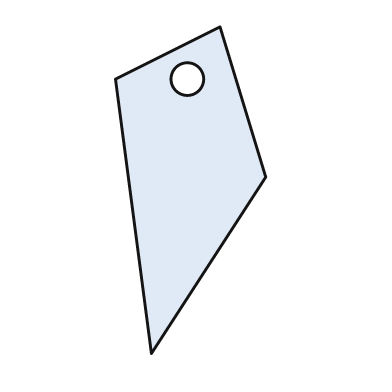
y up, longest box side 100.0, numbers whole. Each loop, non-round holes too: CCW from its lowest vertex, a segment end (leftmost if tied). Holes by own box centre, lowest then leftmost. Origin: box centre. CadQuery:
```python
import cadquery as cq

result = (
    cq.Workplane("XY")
    .moveTo(-12.0, -50.0)
    .lineTo(23.0, 4.0)
    .lineTo(9.0, 50.0)
    .lineTo(-23.0, 34.0)
    .close()
    .moveTo(-1.0, 34.0)
    .circle(5.0)
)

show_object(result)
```